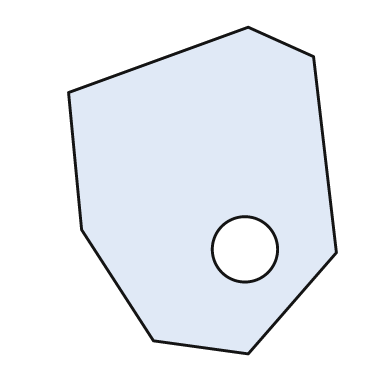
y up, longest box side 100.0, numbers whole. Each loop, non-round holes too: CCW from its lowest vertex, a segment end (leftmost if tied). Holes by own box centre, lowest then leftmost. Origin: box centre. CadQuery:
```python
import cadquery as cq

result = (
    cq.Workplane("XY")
    .moveTo(14.0, -50.0)
    .lineTo(41.0, -19.0)
    .lineTo(34.0, 41.0)
    .lineTo(14.0, 50.0)
    .lineTo(-41.0, 30.0)
    .lineTo(-37.0, -12.0)
    .lineTo(-15.0, -46.0)
    .close()
    .moveTo(13.0, -18.0)
    .circle(10.0)
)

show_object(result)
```